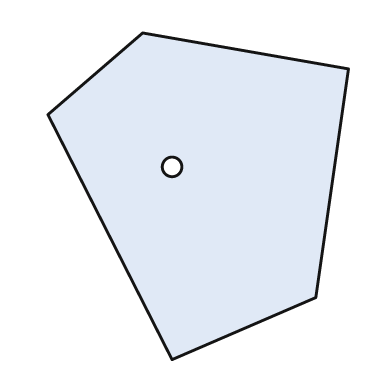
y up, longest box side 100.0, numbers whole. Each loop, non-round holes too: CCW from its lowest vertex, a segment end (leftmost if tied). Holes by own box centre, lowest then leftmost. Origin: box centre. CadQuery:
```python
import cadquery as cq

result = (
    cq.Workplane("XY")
    .moveTo(-8.0, -50.0)
    .lineTo(36.0, -31.0)
    .lineTo(46.0, 39.0)
    .lineTo(-17.0, 50.0)
    .lineTo(-46.0, 25.0)
    .close()
    .moveTo(-8.0, 9.0)
    .circle(3.0)
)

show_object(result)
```